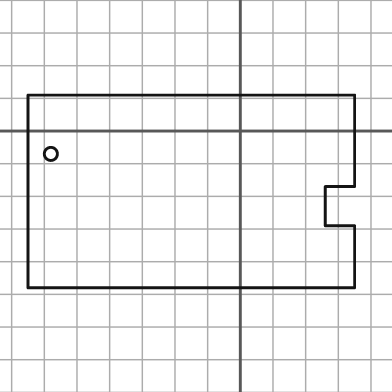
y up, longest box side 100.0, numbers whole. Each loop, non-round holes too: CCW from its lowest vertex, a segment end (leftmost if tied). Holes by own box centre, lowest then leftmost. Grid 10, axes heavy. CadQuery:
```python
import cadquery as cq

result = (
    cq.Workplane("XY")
    .moveTo(-65.0, -48.0)
    .lineTo(35.0, -48.0)
    .lineTo(35.0, -29.0)
    .lineTo(26.0, -29.0)
    .lineTo(26.0, -17.0)
    .lineTo(35.0, -17.0)
    .lineTo(35.0, 11.0)
    .lineTo(-65.0, 11.0)
    .close()
    .moveTo(-58.0, -7.0)
    .circle(2.0)
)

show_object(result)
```